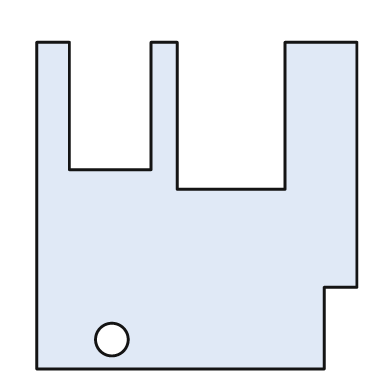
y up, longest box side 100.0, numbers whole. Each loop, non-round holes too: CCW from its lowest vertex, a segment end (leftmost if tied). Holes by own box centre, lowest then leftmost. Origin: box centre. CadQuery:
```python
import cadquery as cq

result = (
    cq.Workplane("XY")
    .moveTo(-49.0, -50.0)
    .lineTo(39.0, -50.0)
    .lineTo(39.0, -25.0)
    .lineTo(49.0, -25.0)
    .lineTo(49.0, 50.0)
    .lineTo(27.0, 50.0)
    .lineTo(27.0, 5.0)
    .lineTo(-6.0, 5.0)
    .lineTo(-6.0, 50.0)
    .lineTo(-14.0, 50.0)
    .lineTo(-14.0, 11.0)
    .lineTo(-39.0, 11.0)
    .lineTo(-39.0, 50.0)
    .lineTo(-49.0, 50.0)
    .close()
    .moveTo(-26.0, -41.0)
    .circle(5.0)
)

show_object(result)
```